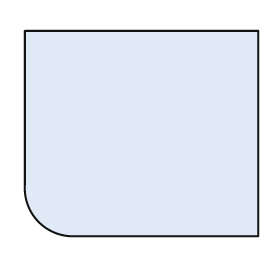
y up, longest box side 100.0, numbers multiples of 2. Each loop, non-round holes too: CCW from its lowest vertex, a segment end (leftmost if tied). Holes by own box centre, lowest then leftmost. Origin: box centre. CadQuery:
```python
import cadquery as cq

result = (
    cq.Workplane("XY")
    .moveTo(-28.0, -44.0)
    .lineTo(50.0, -44.0)
    .lineTo(50.0, 44.0)
    .lineTo(-50.0, 44.0)
    .lineTo(-50.0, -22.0)
    .threePointArc((-44.0, -38.0), (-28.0, -44.0))
    .close()
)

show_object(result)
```